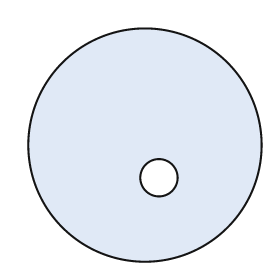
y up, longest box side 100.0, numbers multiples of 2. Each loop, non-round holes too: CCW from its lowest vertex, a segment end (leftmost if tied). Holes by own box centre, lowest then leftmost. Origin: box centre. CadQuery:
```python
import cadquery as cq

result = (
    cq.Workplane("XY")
    .moveTo(0.0, 0.0)
    .circle(50.0)
    .moveTo(6.0, -14.0)
    .circle(8.0)
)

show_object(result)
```